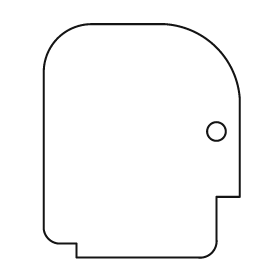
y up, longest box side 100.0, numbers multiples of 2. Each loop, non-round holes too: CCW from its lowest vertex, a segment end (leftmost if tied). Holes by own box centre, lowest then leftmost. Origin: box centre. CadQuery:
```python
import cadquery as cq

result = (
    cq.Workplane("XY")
    .moveTo(-28.0, -50.0)
    .lineTo(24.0, -50.0)
    .threePointArc((30.0, -48.0), (32.0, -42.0))
    .lineTo(32.0, -24.0)
    .lineTo(42.0, -24.0)
    .lineTo(42.0, 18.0)
    .threePointArc((32.0, 40.0), (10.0, 50.0))
    .lineTo(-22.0, 50.0)
    .threePointArc((-36.0, 44.0), (-42.0, 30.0))
    .lineTo(-42.0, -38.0)
    .threePointArc((-40.0, -42.0), (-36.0, -44.0))
    .lineTo(-28.0, -44.0)
    .close()
    .moveTo(32.0, 4.0)
    .circle(4.0)
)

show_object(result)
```